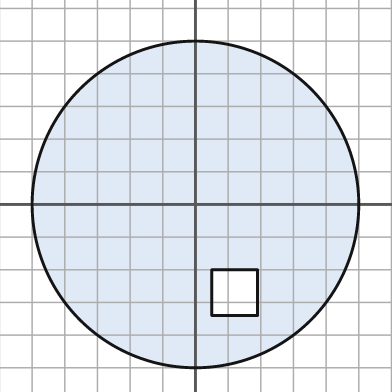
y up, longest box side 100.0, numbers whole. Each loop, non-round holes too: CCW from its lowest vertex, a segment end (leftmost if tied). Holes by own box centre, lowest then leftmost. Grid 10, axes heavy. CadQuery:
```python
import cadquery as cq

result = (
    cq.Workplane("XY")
    .moveTo(0.0, 0.0)
    .circle(50.0)
    .moveTo(5.0, -34.0)
    .lineTo(19.0, -34.0)
    .lineTo(19.0, -20.0)
    .lineTo(5.0, -20.0)
    .close()
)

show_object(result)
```